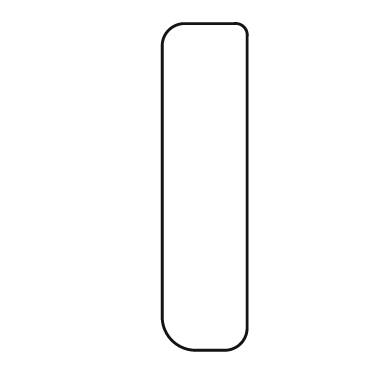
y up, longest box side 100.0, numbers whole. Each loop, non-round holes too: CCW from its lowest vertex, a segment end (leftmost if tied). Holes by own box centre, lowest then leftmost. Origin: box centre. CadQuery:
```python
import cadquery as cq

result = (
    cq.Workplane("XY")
    .moveTo(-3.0, -50.0)
    .lineTo(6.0, -50.0)
    .threePointArc((11.0, -48.0), (13.0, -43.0))
    .lineTo(13.0, 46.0)
    .threePointArc((12.0, 49.0), (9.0, 50.0))
    .lineTo(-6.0, 50.0)
    .threePointArc((-11.0, 48.0), (-13.0, 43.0))
    .lineTo(-13.0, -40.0)
    .threePointArc((-10.0, -47.0), (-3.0, -50.0))
    .close()
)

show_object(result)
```